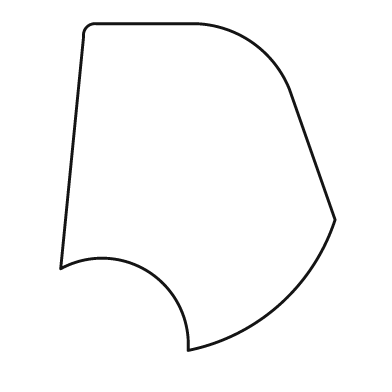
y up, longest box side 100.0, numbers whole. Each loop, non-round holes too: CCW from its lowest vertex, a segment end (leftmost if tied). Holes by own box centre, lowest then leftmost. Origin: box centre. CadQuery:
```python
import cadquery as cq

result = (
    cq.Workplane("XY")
    .moveTo(-3.0, -50.0)
    .threePointArc((25.0, -36.0), (42.0, -10.0))
    .lineTo(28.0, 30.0)
    .threePointArc((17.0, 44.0), (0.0, 50.0))
    .lineTo(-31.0, 50.0)
    .threePointArc((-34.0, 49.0), (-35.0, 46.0))
    .lineTo(-42.0, -25.0)
    .threePointArc((-15.0, -26.0), (-3.0, -50.0))
    .close()
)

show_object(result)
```